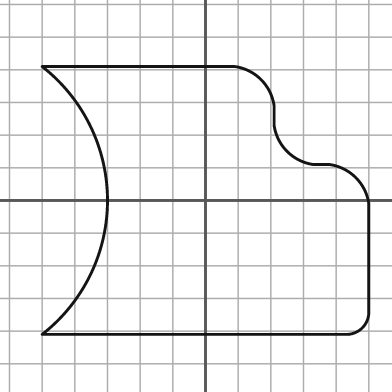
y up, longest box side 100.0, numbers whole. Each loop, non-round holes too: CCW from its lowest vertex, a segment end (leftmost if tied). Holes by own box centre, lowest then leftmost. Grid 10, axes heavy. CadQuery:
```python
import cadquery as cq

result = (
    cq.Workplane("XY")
    .moveTo(-50.0, -41.0)
    .lineTo(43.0, -41.0)
    .threePointArc((48.0, -39.0), (50.0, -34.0))
    .lineTo(50.0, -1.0)
    .threePointArc((46.0, 7.0), (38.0, 11.0))
    .lineTo(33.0, 11.0)
    .threePointArc((25.0, 15.0), (21.0, 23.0))
    .lineTo(21.0, 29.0)
    .threePointArc((17.0, 37.0), (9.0, 41.0))
    .lineTo(-50.0, 41.0)
    .threePointArc((-30.0, 0.0), (-50.0, -41.0))
    .close()
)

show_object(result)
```